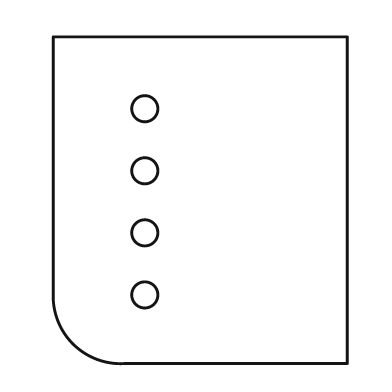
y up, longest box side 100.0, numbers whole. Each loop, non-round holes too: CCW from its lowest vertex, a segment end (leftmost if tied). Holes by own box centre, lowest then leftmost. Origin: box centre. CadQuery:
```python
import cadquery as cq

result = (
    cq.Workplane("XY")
    .moveTo(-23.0, -50.0)
    .lineTo(45.0, -50.0)
    .lineTo(45.0, 50.0)
    .lineTo(-45.0, 50.0)
    .lineTo(-45.0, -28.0)
    .threePointArc((-39.0, -44.0), (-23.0, -50.0))
    .close()
    .moveTo(-17.0, -29.0)
    .circle(4.0)
    .moveTo(-17.0, -10.0)
    .circle(4.0)
    .moveTo(-17.0, 9.0)
    .circle(4.0)
    .moveTo(-17.0, 28.0)
    .circle(4.0)
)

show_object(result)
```